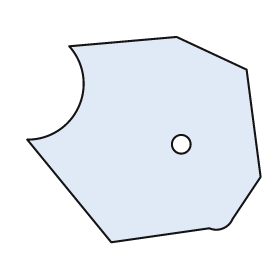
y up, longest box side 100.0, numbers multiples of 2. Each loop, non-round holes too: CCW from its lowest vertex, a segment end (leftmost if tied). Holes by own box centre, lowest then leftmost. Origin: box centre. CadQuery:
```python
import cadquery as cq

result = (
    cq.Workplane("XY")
    .moveTo(-14.0, -44.0)
    .lineTo(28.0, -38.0)
    .threePointArc((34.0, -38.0), (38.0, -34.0))
    .lineTo(50.0, -16.0)
    .lineTo(44.0, 30.0)
    .lineTo(14.0, 44.0)
    .lineTo(-32.0, 40.0)
    .threePointArc((-28.0, 14.0), (-50.0, 0.0))
    .close()
    .moveTo(16.0, -2.0)
    .circle(4.0)
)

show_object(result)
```